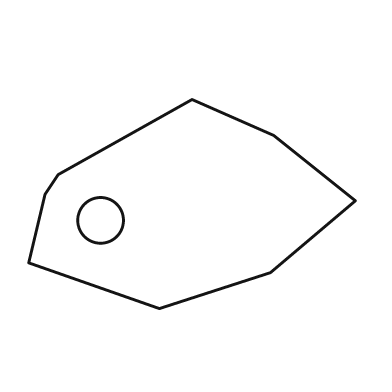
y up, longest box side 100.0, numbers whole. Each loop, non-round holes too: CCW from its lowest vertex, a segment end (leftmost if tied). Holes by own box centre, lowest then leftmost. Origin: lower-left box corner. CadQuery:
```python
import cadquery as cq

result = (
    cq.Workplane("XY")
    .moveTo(40.0, 0.0)
    .lineTo(74.0, 11.0)
    .lineTo(100.0, 33.0)
    .lineTo(75.0, 53.0)
    .lineTo(50.0, 64.0)
    .lineTo(9.0, 41.0)
    .lineTo(5.0, 35.0)
    .lineTo(0.0, 14.0)
    .close()
    .moveTo(22.0, 27.0)
    .circle(7.0)
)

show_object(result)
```